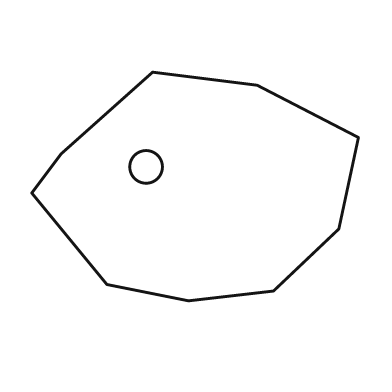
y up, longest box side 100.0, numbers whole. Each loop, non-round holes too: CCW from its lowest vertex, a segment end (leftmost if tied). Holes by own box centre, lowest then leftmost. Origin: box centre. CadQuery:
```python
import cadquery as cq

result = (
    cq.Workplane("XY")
    .moveTo(-2.0, -35.0)
    .lineTo(24.0, -32.0)
    .lineTo(44.0, -13.0)
    .lineTo(50.0, 15.0)
    .lineTo(19.0, 31.0)
    .lineTo(-13.0, 35.0)
    .lineTo(-41.0, 10.0)
    .lineTo(-50.0, -2.0)
    .lineTo(-27.0, -30.0)
    .close()
    .moveTo(-15.0, 6.0)
    .circle(5.0)
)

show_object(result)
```